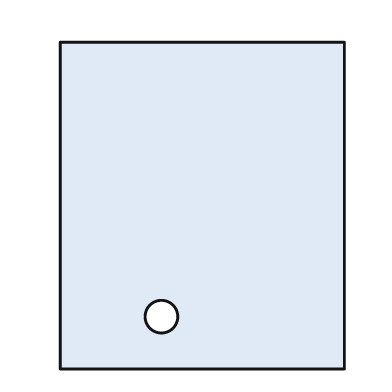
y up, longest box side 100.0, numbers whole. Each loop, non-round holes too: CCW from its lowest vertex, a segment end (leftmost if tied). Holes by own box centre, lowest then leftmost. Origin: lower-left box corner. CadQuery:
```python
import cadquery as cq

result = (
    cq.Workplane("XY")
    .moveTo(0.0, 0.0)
    .lineTo(87.0, 0.0)
    .lineTo(87.0, 100.0)
    .lineTo(0.0, 100.0)
    .close()
    .moveTo(31.0, 16.0)
    .circle(5.0)
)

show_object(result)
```